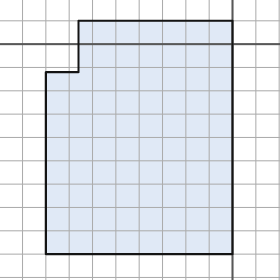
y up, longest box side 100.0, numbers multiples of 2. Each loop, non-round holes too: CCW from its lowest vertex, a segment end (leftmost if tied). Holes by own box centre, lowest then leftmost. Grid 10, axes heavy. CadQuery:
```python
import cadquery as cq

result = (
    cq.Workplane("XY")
    .moveTo(-80.0, -90.0)
    .lineTo(0.0, -90.0)
    .lineTo(0.0, 10.0)
    .lineTo(-66.0, 10.0)
    .lineTo(-66.0, -12.0)
    .lineTo(-80.0, -12.0)
    .close()
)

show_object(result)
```